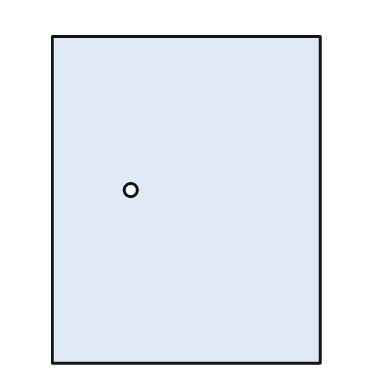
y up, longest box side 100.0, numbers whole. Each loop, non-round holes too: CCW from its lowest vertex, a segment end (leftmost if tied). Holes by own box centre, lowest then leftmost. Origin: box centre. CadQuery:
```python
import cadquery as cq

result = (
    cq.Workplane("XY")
    .moveTo(-41.0, -50.0)
    .lineTo(41.0, -50.0)
    .lineTo(41.0, 50.0)
    .lineTo(-41.0, 50.0)
    .close()
    .moveTo(-17.0, 3.0)
    .circle(2.0)
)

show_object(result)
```